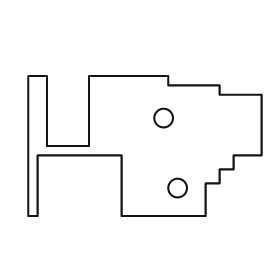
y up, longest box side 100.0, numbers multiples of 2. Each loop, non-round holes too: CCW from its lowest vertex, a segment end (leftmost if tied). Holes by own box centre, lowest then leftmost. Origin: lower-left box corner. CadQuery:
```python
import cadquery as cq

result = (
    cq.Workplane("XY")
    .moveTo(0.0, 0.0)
    .lineTo(4.0, 0.0)
    .lineTo(4.0, 26.0)
    .lineTo(40.0, 26.0)
    .lineTo(40.0, 0.0)
    .lineTo(76.0, 0.0)
    .lineTo(76.0, 14.0)
    .lineTo(82.0, 14.0)
    .lineTo(82.0, 20.0)
    .lineTo(88.0, 20.0)
    .lineTo(88.0, 26.0)
    .lineTo(100.0, 26.0)
    .lineTo(100.0, 52.0)
    .lineTo(82.0, 52.0)
    .lineTo(82.0, 56.0)
    .lineTo(60.0, 56.0)
    .lineTo(60.0, 60.0)
    .lineTo(26.0, 60.0)
    .lineTo(26.0, 30.0)
    .lineTo(8.0, 30.0)
    .lineTo(8.0, 60.0)
    .lineTo(0.0, 60.0)
    .close()
    .moveTo(64.0, 12.0)
    .circle(4.0)
    .moveTo(58.0, 42.0)
    .circle(4.0)
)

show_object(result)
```